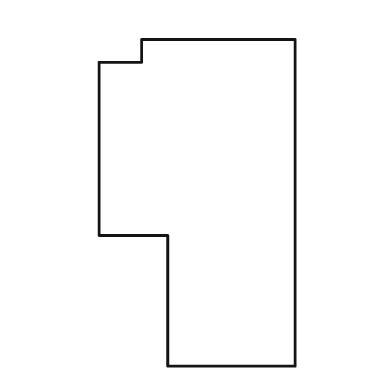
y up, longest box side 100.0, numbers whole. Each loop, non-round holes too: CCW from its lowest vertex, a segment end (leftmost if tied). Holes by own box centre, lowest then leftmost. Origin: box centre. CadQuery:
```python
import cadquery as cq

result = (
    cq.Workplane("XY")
    .moveTo(-9.0, -50.0)
    .lineTo(30.0, -50.0)
    .lineTo(30.0, 50.0)
    .lineTo(-17.0, 50.0)
    .lineTo(-17.0, 43.0)
    .lineTo(-30.0, 43.0)
    .lineTo(-30.0, -10.0)
    .lineTo(-9.0, -10.0)
    .close()
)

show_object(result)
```